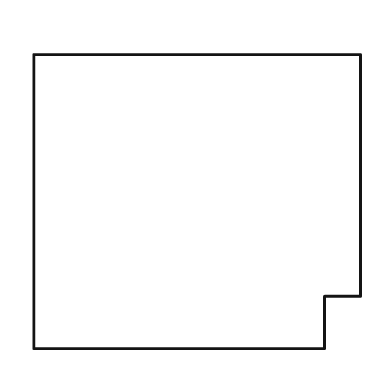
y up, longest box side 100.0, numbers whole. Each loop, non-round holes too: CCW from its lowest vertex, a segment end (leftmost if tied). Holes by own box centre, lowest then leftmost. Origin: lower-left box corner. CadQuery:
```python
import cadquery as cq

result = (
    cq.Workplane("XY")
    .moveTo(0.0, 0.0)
    .lineTo(89.0, 0.0)
    .lineTo(89.0, 16.0)
    .lineTo(100.0, 16.0)
    .lineTo(100.0, 90.0)
    .lineTo(0.0, 90.0)
    .close()
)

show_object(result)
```